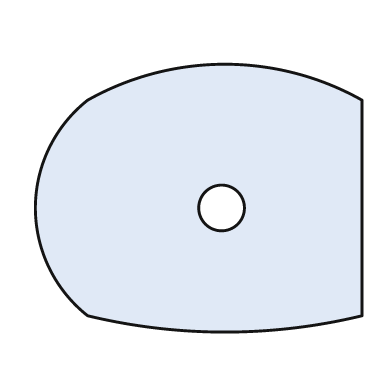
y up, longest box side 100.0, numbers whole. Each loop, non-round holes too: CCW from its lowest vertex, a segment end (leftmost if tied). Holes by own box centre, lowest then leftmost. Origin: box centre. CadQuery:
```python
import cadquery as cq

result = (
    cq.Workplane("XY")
    .moveTo(-34.0, -36.0)
    .threePointArc((8.0, -41.0), (50.0, -36.0))
    .lineTo(50.0, 30.0)
    .threePointArc((8.0, 41.0), (-34.0, 30.0))
    .threePointArc((-50.0, -3.0), (-34.0, -36.0))
    .close()
    .moveTo(7.0, -3.0)
    .circle(7.0)
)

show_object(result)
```